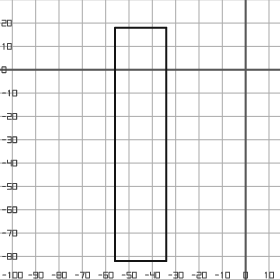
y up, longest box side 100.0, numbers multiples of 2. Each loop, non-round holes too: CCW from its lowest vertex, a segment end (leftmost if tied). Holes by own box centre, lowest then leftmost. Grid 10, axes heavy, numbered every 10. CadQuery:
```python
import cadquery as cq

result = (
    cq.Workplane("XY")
    .moveTo(-56.0, -82.0)
    .lineTo(-34.0, -82.0)
    .lineTo(-34.0, 18.0)
    .lineTo(-56.0, 18.0)
    .close()
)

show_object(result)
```